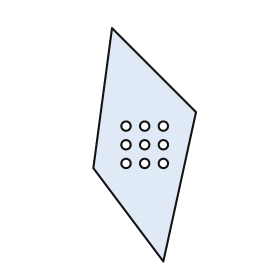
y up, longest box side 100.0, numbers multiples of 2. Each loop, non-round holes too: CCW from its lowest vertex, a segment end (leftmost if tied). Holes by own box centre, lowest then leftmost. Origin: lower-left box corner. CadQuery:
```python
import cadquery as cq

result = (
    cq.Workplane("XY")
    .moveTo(30.0, 0.0)
    .lineTo(44.0, 64.0)
    .lineTo(8.0, 100.0)
    .lineTo(0.0, 40.0)
    .close()
    .moveTo(14.0, 42.0)
    .circle(2.0)
    .moveTo(22.0, 42.0)
    .circle(2.0)
    .moveTo(30.0, 42.0)
    .circle(2.0)
    .moveTo(14.0, 50.0)
    .circle(2.0)
    .moveTo(22.0, 50.0)
    .circle(2.0)
    .moveTo(30.0, 50.0)
    .circle(2.0)
    .moveTo(14.0, 58.0)
    .circle(2.0)
    .moveTo(22.0, 58.0)
    .circle(2.0)
    .moveTo(30.0, 58.0)
    .circle(2.0)
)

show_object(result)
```